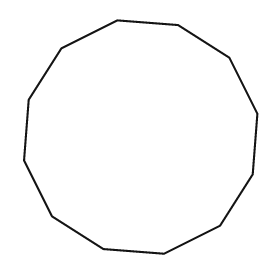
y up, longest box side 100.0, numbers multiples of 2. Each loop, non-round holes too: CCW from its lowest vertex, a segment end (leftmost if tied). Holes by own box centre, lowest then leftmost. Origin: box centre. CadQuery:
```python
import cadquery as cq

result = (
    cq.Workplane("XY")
    .moveTo(10.0, -50.0)
    .lineTo(34.0, -38.0)
    .lineTo(48.0, -16.0)
    .lineTo(50.0, 10.0)
    .lineTo(38.0, 34.0)
    .lineTo(16.0, 48.0)
    .lineTo(-10.0, 50.0)
    .lineTo(-34.0, 38.0)
    .lineTo(-48.0, 16.0)
    .lineTo(-50.0, -10.0)
    .lineTo(-38.0, -34.0)
    .lineTo(-16.0, -48.0)
    .close()
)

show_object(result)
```